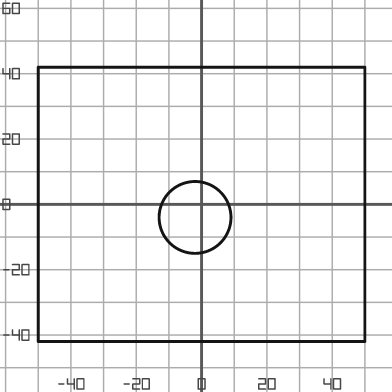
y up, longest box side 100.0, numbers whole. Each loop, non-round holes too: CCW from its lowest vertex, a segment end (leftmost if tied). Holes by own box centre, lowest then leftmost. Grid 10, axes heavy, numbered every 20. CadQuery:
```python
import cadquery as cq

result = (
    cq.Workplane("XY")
    .moveTo(-50.0, -42.0)
    .lineTo(50.0, -42.0)
    .lineTo(50.0, 42.0)
    .lineTo(-50.0, 42.0)
    .close()
    .moveTo(-2.0, -4.0)
    .circle(11.0)
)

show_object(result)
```